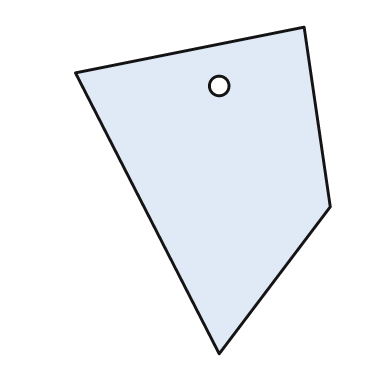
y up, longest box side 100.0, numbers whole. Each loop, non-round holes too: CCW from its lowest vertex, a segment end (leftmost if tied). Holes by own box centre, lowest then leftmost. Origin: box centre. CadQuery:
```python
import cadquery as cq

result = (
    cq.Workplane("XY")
    .moveTo(5.0, -50.0)
    .lineTo(39.0, -5.0)
    .lineTo(31.0, 50.0)
    .lineTo(-39.0, 36.0)
    .close()
    .moveTo(5.0, 32.0)
    .circle(3.0)
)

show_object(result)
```